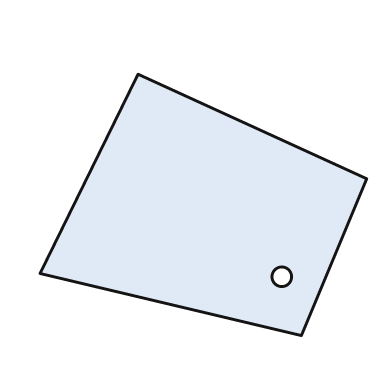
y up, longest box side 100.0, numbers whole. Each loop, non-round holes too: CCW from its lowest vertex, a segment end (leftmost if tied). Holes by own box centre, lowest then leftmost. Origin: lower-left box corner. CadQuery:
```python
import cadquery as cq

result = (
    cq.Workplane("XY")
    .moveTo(80.0, 0.0)
    .lineTo(100.0, 48.0)
    .lineTo(30.0, 80.0)
    .lineTo(0.0, 19.0)
    .close()
    .moveTo(74.0, 18.0)
    .circle(3.0)
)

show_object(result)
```